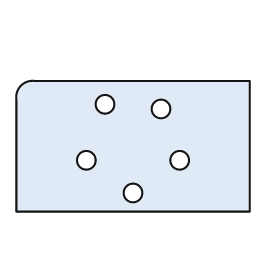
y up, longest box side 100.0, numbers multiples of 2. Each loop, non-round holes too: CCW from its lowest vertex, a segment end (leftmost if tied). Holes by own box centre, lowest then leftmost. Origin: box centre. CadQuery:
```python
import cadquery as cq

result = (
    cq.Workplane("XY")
    .moveTo(-50.0, -28.0)
    .lineTo(50.0, -28.0)
    .lineTo(50.0, 28.0)
    .lineTo(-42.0, 28.0)
    .threePointArc((-48.0, 26.0), (-50.0, 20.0))
    .close()
    .moveTo(0.0, -20.0)
    .circle(4.0)
    .moveTo(-20.0, -6.0)
    .circle(4.0)
    .moveTo(20.0, -6.0)
    .circle(4.0)
    .moveTo(12.0, 16.0)
    .circle(4.0)
    .moveTo(-12.0, 18.0)
    .circle(4.0)
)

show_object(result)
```